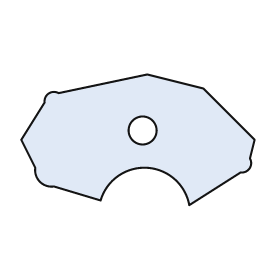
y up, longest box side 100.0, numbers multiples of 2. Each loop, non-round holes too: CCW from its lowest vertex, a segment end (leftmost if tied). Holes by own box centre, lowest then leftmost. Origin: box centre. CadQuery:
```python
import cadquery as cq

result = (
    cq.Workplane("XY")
    .moveTo(22.0, -28.0)
    .lineTo(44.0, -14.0)
    .threePointArc((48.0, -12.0), (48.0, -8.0))
    .lineTo(50.0, 0.0)
    .lineTo(28.0, 22.0)
    .lineTo(4.0, 28.0)
    .lineTo(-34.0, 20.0)
    .threePointArc((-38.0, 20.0), (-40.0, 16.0))
    .lineTo(-50.0, 0.0)
    .lineTo(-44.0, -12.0)
    .threePointArc((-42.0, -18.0), (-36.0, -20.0))
    .lineTo(-16.0, -26.0)
    .threePointArc((4.0, -12.0), (22.0, -28.0))
    .close()
    .moveTo(2.0, 4.0)
    .circle(6.0)
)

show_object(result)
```